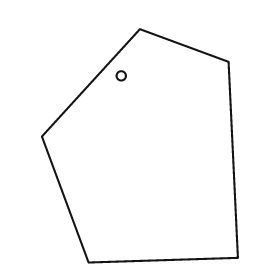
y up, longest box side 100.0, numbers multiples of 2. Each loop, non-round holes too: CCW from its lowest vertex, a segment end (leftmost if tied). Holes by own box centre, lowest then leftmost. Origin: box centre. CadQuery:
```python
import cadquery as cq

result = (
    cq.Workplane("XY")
    .moveTo(-22.0, -50.0)
    .lineTo(42.0, -48.0)
    .lineTo(38.0, 36.0)
    .lineTo(0.0, 50.0)
    .lineTo(-42.0, 4.0)
    .close()
    .moveTo(-8.0, 30.0)
    .circle(2.0)
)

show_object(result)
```